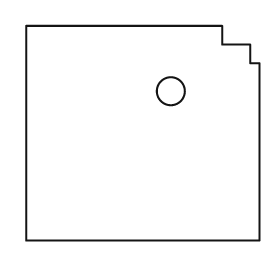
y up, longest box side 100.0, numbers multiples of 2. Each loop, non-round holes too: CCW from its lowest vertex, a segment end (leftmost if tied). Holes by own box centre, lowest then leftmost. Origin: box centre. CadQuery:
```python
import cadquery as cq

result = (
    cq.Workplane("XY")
    .moveTo(-50.0, -46.0)
    .lineTo(50.0, -46.0)
    .lineTo(50.0, 30.0)
    .lineTo(46.0, 30.0)
    .lineTo(46.0, 38.0)
    .lineTo(34.0, 38.0)
    .lineTo(34.0, 46.0)
    .lineTo(-50.0, 46.0)
    .close()
    .moveTo(12.0, 18.0)
    .circle(6.0)
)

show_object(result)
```